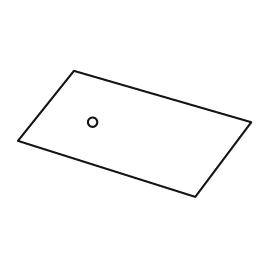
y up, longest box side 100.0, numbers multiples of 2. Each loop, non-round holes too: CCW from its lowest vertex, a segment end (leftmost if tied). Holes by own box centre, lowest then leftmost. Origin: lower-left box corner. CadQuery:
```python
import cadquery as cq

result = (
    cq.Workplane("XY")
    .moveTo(76.0, 0.0)
    .lineTo(100.0, 32.0)
    .lineTo(24.0, 54.0)
    .lineTo(0.0, 24.0)
    .close()
    .moveTo(32.0, 32.0)
    .circle(2.0)
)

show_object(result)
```